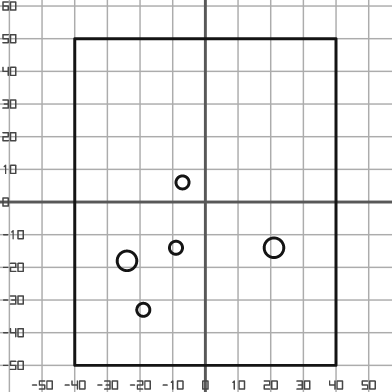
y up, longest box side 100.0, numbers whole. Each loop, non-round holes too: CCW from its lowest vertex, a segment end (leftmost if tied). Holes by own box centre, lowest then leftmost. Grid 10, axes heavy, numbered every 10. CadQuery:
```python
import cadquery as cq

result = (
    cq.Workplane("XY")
    .moveTo(-40.0, -50.0)
    .lineTo(40.0, -50.0)
    .lineTo(40.0, 50.0)
    .lineTo(-40.0, 50.0)
    .close()
    .moveTo(-19.0, -33.0)
    .circle(2.0)
    .moveTo(-24.0, -18.0)
    .circle(3.0)
    .moveTo(-9.0, -14.0)
    .circle(2.0)
    .moveTo(21.0, -14.0)
    .circle(3.0)
    .moveTo(-7.0, 6.0)
    .circle(2.0)
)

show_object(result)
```